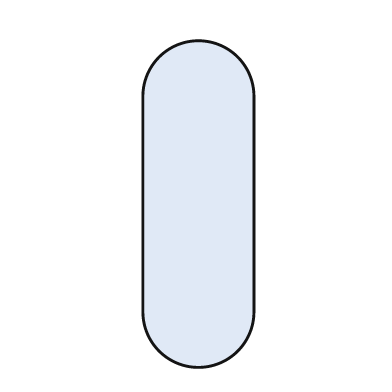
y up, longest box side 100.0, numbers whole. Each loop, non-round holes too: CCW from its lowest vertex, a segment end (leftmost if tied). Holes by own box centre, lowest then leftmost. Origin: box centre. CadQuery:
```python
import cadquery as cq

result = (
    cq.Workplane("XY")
    .moveTo(-17.0, -33.0)
    .threePointArc((0.0, -50.0), (17.0, -33.0))
    .lineTo(17.0, 33.0)
    .threePointArc((0.0, 50.0), (-17.0, 33.0))
    .close()
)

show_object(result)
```